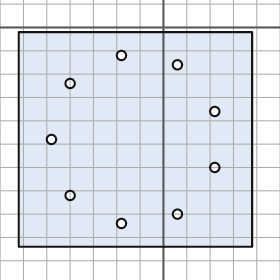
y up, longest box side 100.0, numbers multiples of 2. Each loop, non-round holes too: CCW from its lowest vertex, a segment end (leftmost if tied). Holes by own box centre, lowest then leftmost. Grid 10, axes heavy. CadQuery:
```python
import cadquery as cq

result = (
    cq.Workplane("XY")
    .moveTo(-62.0, -94.0)
    .lineTo(38.0, -94.0)
    .lineTo(38.0, -2.0)
    .lineTo(-62.0, -2.0)
    .close()
    .moveTo(-18.0, -84.0)
    .circle(2.0)
    .moveTo(6.0, -80.0)
    .circle(2.0)
    .moveTo(-40.0, -72.0)
    .circle(2.0)
    .moveTo(22.0, -60.0)
    .circle(2.0)
    .moveTo(-48.0, -48.0)
    .circle(2.0)
    .moveTo(22.0, -36.0)
    .circle(2.0)
    .moveTo(-40.0, -24.0)
    .circle(2.0)
    .moveTo(6.0, -16.0)
    .circle(2.0)
    .moveTo(-18.0, -12.0)
    .circle(2.0)
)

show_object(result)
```